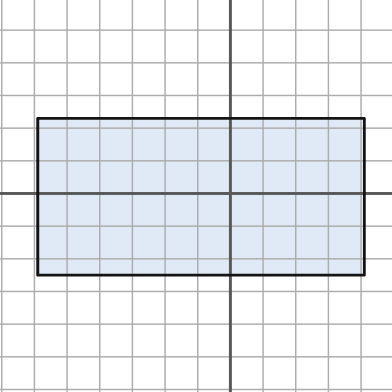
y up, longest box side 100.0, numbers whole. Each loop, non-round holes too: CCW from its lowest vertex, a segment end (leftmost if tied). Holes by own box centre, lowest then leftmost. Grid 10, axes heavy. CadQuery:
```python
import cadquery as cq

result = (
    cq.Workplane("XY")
    .moveTo(-59.0, -25.0)
    .lineTo(41.0, -25.0)
    .lineTo(41.0, 23.0)
    .lineTo(-59.0, 23.0)
    .close()
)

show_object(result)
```